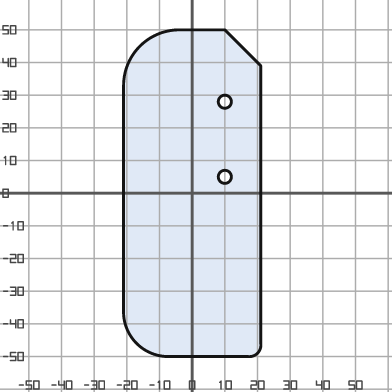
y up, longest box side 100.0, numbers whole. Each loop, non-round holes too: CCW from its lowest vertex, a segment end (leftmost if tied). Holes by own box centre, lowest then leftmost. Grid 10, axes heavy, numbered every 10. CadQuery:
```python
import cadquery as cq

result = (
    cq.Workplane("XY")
    .moveTo(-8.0, -50.0)
    .lineTo(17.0, -50.0)
    .threePointArc((20.0, -49.0), (21.0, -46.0))
    .lineTo(21.0, 39.0)
    .lineTo(10.0, 50.0)
    .lineTo(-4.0, 50.0)
    .threePointArc((-16.0, 45.0), (-21.0, 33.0))
    .lineTo(-21.0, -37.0)
    .threePointArc((-17.0, -46.0), (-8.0, -50.0))
    .close()
    .moveTo(10.0, 5.0)
    .circle(2.0)
    .moveTo(10.0, 28.0)
    .circle(2.0)
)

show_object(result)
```